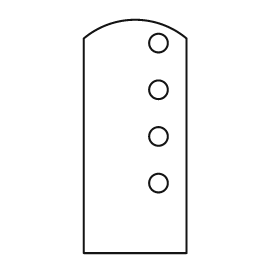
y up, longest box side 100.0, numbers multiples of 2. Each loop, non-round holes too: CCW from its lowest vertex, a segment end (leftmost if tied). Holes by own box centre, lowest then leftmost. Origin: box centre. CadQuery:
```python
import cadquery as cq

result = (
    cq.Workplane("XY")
    .moveTo(-22.0, -50.0)
    .lineTo(22.0, -50.0)
    .lineTo(22.0, 42.0)
    .threePointArc((0.0, 50.0), (-22.0, 42.0))
    .close()
    .moveTo(10.0, -20.0)
    .circle(4.0)
    .moveTo(10.0, 0.0)
    .circle(4.0)
    .moveTo(10.0, 20.0)
    .circle(4.0)
    .moveTo(10.0, 40.0)
    .circle(4.0)
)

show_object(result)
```